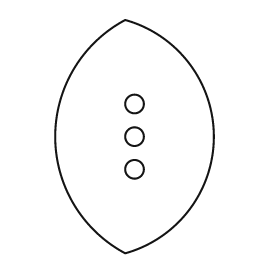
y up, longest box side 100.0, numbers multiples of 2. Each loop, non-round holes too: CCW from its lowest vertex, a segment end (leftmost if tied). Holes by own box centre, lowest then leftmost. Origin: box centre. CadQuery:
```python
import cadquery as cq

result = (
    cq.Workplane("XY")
    .moveTo(-4.0, -50.0)
    .threePointArc((34.0, 0.0), (-4.0, 50.0))
    .threePointArc((-34.0, 0.0), (-4.0, -50.0))
    .close()
    .moveTo(0.0, -14.0)
    .circle(4.0)
    .moveTo(0.0, 0.0)
    .circle(4.0)
    .moveTo(0.0, 14.0)
    .circle(4.0)
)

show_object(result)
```